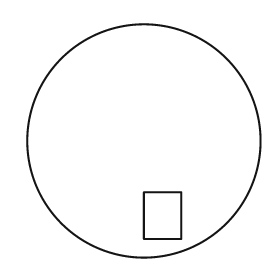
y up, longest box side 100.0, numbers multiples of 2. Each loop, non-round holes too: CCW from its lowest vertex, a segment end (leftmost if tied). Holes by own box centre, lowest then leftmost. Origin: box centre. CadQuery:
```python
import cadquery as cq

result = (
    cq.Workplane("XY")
    .moveTo(0.0, 0.0)
    .circle(50.0)
    .moveTo(0.0, -42.0)
    .lineTo(16.0, -42.0)
    .lineTo(16.0, -22.0)
    .lineTo(0.0, -22.0)
    .close()
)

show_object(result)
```